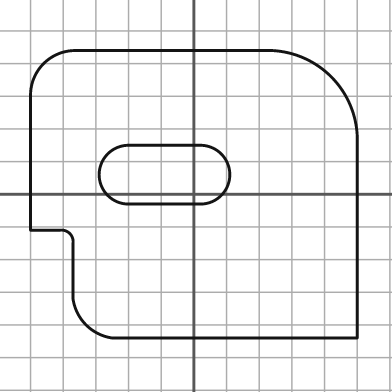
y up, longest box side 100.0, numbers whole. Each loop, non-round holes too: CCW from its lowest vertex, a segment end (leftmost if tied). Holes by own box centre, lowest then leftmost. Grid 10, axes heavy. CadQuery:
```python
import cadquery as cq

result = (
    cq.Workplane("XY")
    .moveTo(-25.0, -44.0)
    .lineTo(50.0, -44.0)
    .lineTo(50.0, 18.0)
    .threePointArc((42.0, 36.0), (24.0, 44.0))
    .lineTo(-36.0, 44.0)
    .threePointArc((-46.0, 40.0), (-50.0, 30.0))
    .lineTo(-50.0, -11.0)
    .lineTo(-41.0, -11.0)
    .threePointArc((-38.0, -12.0), (-37.0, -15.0))
    .lineTo(-37.0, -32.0)
    .threePointArc((-33.0, -40.0), (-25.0, -44.0))
    .close()
    .moveTo(-20.0, -3.0)
    .lineTo(2.0, -3.0)
    .threePointArc((11.0, 6.0), (2.0, 15.0))
    .lineTo(-20.0, 15.0)
    .threePointArc((-29.0, 6.0), (-20.0, -3.0))
    .close()
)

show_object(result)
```